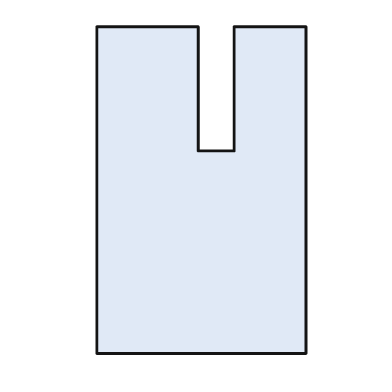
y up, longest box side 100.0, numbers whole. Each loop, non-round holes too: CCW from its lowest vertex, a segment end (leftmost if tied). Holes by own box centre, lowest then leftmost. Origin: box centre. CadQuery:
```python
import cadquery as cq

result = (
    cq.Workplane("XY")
    .moveTo(-32.0, -50.0)
    .lineTo(32.0, -50.0)
    .lineTo(32.0, 50.0)
    .lineTo(10.0, 50.0)
    .lineTo(10.0, 12.0)
    .lineTo(-1.0, 12.0)
    .lineTo(-1.0, 50.0)
    .lineTo(-32.0, 50.0)
    .close()
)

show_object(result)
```